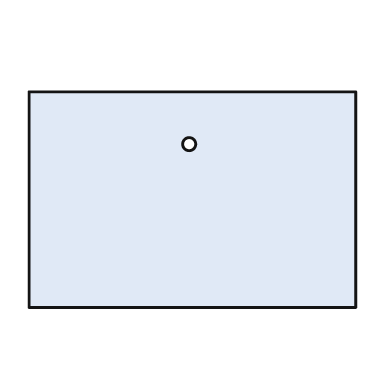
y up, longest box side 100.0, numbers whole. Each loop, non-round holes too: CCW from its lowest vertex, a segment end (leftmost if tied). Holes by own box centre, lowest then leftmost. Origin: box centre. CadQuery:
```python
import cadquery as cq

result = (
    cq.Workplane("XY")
    .moveTo(-50.0, -33.0)
    .lineTo(50.0, -33.0)
    .lineTo(50.0, 33.0)
    .lineTo(-50.0, 33.0)
    .close()
    .moveTo(-1.0, 17.0)
    .circle(2.0)
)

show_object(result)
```